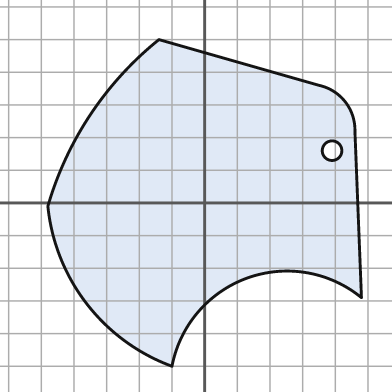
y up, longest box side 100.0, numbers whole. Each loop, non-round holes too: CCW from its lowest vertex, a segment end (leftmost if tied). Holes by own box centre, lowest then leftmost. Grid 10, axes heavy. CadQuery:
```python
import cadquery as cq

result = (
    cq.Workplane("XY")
    .moveTo(-10.0, -50.0)
    .threePointArc((13.0, -23.0), (48.0, -29.0))
    .lineTo(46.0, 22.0)
    .threePointArc((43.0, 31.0), (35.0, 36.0))
    .lineTo(-14.0, 50.0)
    .threePointArc((-35.0, 27.0), (-48.0, -1.0))
    .threePointArc((-36.0, -31.0), (-10.0, -50.0))
    .close()
    .moveTo(39.0, 16.0)
    .circle(3.0)
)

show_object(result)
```